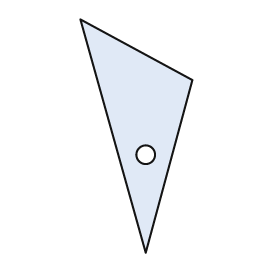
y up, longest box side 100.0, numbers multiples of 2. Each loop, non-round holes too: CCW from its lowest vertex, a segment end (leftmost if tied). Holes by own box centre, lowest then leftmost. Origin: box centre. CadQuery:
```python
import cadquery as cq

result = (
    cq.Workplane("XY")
    .moveTo(4.0, -50.0)
    .lineTo(24.0, 24.0)
    .lineTo(-24.0, 50.0)
    .close()
    .moveTo(4.0, -8.0)
    .circle(4.0)
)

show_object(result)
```